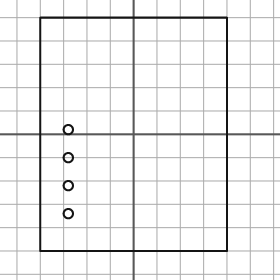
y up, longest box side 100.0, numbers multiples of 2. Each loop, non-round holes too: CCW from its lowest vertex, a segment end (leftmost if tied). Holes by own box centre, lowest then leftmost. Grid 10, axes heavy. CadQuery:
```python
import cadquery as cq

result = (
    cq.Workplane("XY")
    .moveTo(-40.0, -50.0)
    .lineTo(40.0, -50.0)
    .lineTo(40.0, 50.0)
    .lineTo(-40.0, 50.0)
    .close()
    .moveTo(-28.0, -34.0)
    .circle(2.0)
    .moveTo(-28.0, -22.0)
    .circle(2.0)
    .moveTo(-28.0, -10.0)
    .circle(2.0)
    .moveTo(-28.0, 2.0)
    .circle(2.0)
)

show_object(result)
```